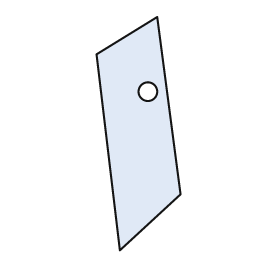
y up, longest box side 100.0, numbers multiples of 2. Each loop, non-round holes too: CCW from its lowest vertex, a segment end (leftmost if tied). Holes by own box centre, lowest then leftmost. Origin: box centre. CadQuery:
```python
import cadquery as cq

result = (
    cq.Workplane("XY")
    .moveTo(-8.0, -50.0)
    .lineTo(18.0, -26.0)
    .lineTo(8.0, 50.0)
    .lineTo(-18.0, 34.0)
    .close()
    .moveTo(4.0, 18.0)
    .circle(4.0)
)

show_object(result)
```